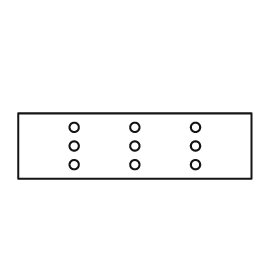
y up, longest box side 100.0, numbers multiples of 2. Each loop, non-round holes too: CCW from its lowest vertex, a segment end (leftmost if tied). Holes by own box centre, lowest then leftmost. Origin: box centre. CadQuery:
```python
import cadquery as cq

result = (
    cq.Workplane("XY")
    .moveTo(-50.0, -14.0)
    .lineTo(50.0, -14.0)
    .lineTo(50.0, 14.0)
    .lineTo(-50.0, 14.0)
    .close()
    .moveTo(-26.0, -8.0)
    .circle(2.0)
    .moveTo(0.0, -8.0)
    .circle(2.0)
    .moveTo(26.0, -8.0)
    .circle(2.0)
    .moveTo(-26.0, 0.0)
    .circle(2.0)
    .moveTo(0.0, 0.0)
    .circle(2.0)
    .moveTo(26.0, 0.0)
    .circle(2.0)
    .moveTo(-26.0, 8.0)
    .circle(2.0)
    .moveTo(0.0, 8.0)
    .circle(2.0)
    .moveTo(26.0, 8.0)
    .circle(2.0)
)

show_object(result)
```